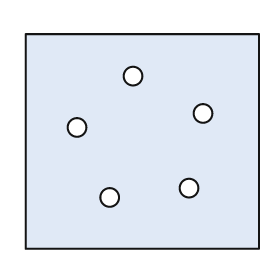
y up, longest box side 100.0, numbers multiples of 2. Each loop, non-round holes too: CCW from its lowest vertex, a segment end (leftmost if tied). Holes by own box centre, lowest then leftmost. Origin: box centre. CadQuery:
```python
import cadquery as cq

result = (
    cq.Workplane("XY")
    .moveTo(-50.0, -46.0)
    .lineTo(50.0, -46.0)
    .lineTo(50.0, 46.0)
    .lineTo(-50.0, 46.0)
    .close()
    .moveTo(-14.0, -24.0)
    .circle(4.0)
    .moveTo(20.0, -20.0)
    .circle(4.0)
    .moveTo(-28.0, 6.0)
    .circle(4.0)
    .moveTo(26.0, 12.0)
    .circle(4.0)
    .moveTo(-4.0, 28.0)
    .circle(4.0)
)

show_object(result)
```